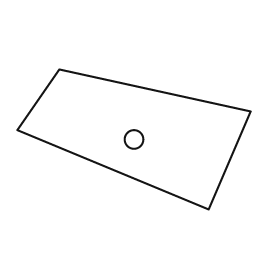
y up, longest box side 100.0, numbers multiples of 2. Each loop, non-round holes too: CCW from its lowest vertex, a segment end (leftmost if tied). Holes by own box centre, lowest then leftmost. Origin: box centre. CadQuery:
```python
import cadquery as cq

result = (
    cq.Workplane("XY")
    .moveTo(32.0, -30.0)
    .lineTo(50.0, 12.0)
    .lineTo(-32.0, 30.0)
    .lineTo(-50.0, 4.0)
    .close()
    .moveTo(0.0, 0.0)
    .circle(4.0)
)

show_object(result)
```